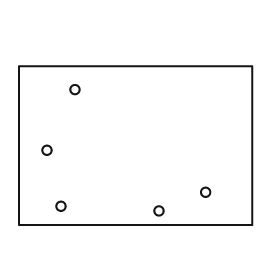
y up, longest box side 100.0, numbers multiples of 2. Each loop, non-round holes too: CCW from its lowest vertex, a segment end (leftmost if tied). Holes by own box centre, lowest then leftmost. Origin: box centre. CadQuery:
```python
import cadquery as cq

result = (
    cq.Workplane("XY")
    .moveTo(-50.0, -34.0)
    .lineTo(50.0, -34.0)
    .lineTo(50.0, 34.0)
    .lineTo(-50.0, 34.0)
    .close()
    .moveTo(10.0, -28.0)
    .circle(2.0)
    .moveTo(-32.0, -26.0)
    .circle(2.0)
    .moveTo(30.0, -20.0)
    .circle(2.0)
    .moveTo(-38.0, -2.0)
    .circle(2.0)
    .moveTo(-26.0, 24.0)
    .circle(2.0)
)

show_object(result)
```